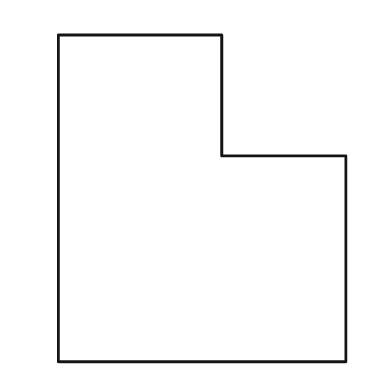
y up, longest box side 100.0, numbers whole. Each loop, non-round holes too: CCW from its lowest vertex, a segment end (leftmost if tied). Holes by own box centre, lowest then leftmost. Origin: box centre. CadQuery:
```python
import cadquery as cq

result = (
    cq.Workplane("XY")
    .moveTo(-44.0, -50.0)
    .lineTo(44.0, -50.0)
    .lineTo(44.0, 13.0)
    .lineTo(6.0, 13.0)
    .lineTo(6.0, 50.0)
    .lineTo(-44.0, 50.0)
    .close()
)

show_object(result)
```